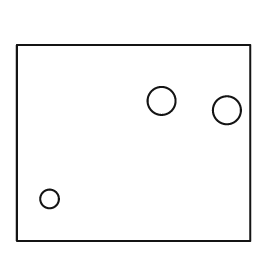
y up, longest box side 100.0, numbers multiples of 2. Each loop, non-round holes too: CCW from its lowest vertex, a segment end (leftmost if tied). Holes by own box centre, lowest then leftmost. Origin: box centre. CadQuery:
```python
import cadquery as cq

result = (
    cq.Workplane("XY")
    .moveTo(-50.0, -42.0)
    .lineTo(50.0, -42.0)
    .lineTo(50.0, 42.0)
    .lineTo(-50.0, 42.0)
    .close()
    .moveTo(-36.0, -24.0)
    .circle(4.0)
    .moveTo(40.0, 14.0)
    .circle(6.0)
    .moveTo(12.0, 18.0)
    .circle(6.0)
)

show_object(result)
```